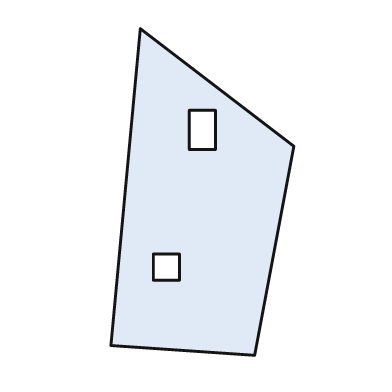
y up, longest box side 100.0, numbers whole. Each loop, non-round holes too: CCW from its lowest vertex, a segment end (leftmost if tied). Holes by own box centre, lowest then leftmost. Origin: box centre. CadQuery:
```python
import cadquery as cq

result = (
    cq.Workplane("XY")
    .moveTo(16.0, -50.0)
    .lineTo(28.0, 14.0)
    .lineTo(-19.0, 50.0)
    .lineTo(-28.0, -47.0)
    .close()
    .moveTo(-15.0, -27.0)
    .lineTo(-7.0, -27.0)
    .lineTo(-7.0, -19.0)
    .lineTo(-15.0, -19.0)
    .close()
    .moveTo(-4.0, 13.0)
    .lineTo(4.0, 13.0)
    .lineTo(4.0, 25.0)
    .lineTo(-4.0, 25.0)
    .close()
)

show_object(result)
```